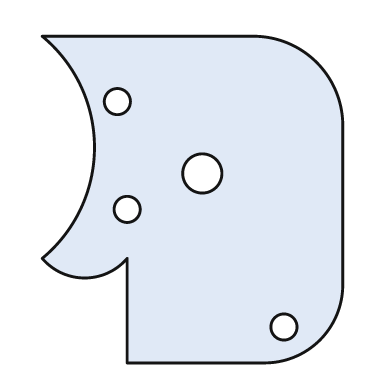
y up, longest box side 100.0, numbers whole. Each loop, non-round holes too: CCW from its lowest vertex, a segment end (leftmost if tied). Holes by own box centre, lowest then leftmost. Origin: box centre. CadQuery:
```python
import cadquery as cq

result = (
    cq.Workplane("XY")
    .moveTo(-20.0, -50.0)
    .lineTo(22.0, -50.0)
    .threePointArc((39.0, -43.0), (46.0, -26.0))
    .lineTo(46.0, 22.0)
    .threePointArc((38.0, 42.0), (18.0, 50.0))
    .lineTo(-46.0, 50.0)
    .threePointArc((-30.0, 16.0), (-46.0, -18.0))
    .threePointArc((-33.0, -24.0), (-20.0, -18.0))
    .close()
    .moveTo(28.0, -39.0)
    .circle(4.0)
    .moveTo(-20.0, -3.0)
    .circle(4.0)
    .moveTo(3.0, 8.0)
    .circle(6.0)
    .moveTo(-23.0, 30.0)
    .circle(4.0)
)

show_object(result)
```